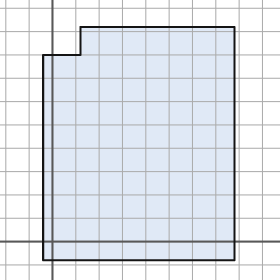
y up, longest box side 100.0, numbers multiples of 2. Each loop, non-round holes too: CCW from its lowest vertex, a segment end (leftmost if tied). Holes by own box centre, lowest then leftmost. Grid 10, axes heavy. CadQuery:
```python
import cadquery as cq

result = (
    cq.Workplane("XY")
    .moveTo(-4.0, -8.0)
    .lineTo(78.0, -8.0)
    .lineTo(78.0, 92.0)
    .lineTo(12.0, 92.0)
    .lineTo(12.0, 80.0)
    .lineTo(-4.0, 80.0)
    .close()
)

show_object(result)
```